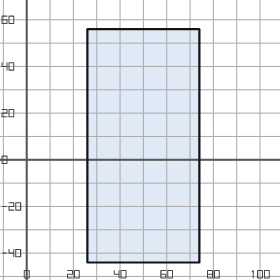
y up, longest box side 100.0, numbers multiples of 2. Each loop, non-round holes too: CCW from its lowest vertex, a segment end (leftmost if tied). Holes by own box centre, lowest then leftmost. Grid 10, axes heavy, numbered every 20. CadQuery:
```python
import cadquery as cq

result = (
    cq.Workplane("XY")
    .moveTo(26.0, -44.0)
    .lineTo(74.0, -44.0)
    .lineTo(74.0, 56.0)
    .lineTo(26.0, 56.0)
    .close()
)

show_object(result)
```